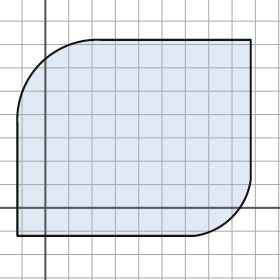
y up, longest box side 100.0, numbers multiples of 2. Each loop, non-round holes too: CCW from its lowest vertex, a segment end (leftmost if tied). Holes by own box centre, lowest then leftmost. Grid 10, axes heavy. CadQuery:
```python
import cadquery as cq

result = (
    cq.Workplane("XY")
    .moveTo(-12.0, -12.0)
    .lineTo(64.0, -12.0)
    .threePointArc((80.0, -4.0), (88.0, 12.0))
    .lineTo(88.0, 72.0)
    .lineTo(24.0, 72.0)
    .threePointArc((-2.0, 62.0), (-12.0, 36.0))
    .close()
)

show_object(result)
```